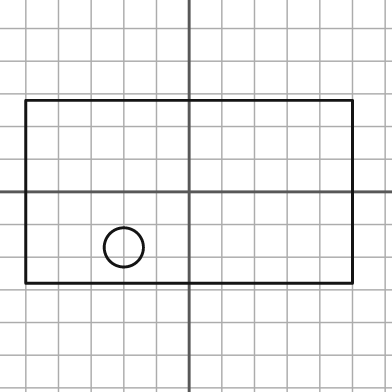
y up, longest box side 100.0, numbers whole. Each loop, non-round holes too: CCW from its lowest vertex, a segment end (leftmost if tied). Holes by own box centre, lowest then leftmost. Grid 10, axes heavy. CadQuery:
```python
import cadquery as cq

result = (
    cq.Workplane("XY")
    .moveTo(-50.0, -28.0)
    .lineTo(50.0, -28.0)
    .lineTo(50.0, 28.0)
    .lineTo(-50.0, 28.0)
    .close()
    .moveTo(-20.0, -17.0)
    .circle(6.0)
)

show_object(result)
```